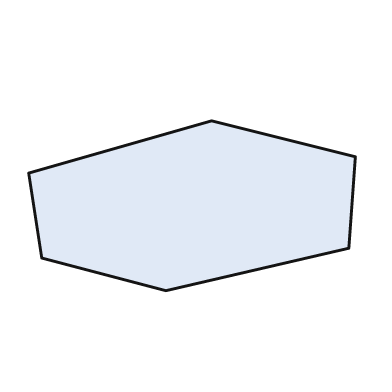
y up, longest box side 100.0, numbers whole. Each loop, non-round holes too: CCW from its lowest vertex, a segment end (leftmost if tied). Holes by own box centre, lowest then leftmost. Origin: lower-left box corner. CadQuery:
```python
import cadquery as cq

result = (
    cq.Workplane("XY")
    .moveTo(42.0, 0.0)
    .lineTo(98.0, 13.0)
    .lineTo(100.0, 41.0)
    .lineTo(56.0, 52.0)
    .lineTo(0.0, 36.0)
    .lineTo(4.0, 10.0)
    .close()
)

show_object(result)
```